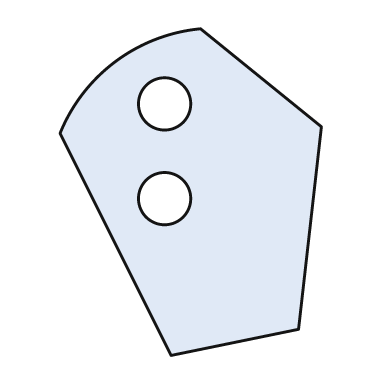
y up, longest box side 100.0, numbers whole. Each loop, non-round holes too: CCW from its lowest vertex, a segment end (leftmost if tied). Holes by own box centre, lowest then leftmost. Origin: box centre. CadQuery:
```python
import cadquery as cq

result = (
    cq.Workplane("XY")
    .moveTo(-6.0, -50.0)
    .lineTo(33.0, -42.0)
    .lineTo(40.0, 20.0)
    .lineTo(3.0, 50.0)
    .threePointArc((-23.0, 40.0), (-40.0, 18.0))
    .close()
    .moveTo(-8.0, -2.0)
    .circle(8.0)
    .moveTo(-8.0, 27.0)
    .circle(8.0)
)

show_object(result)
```